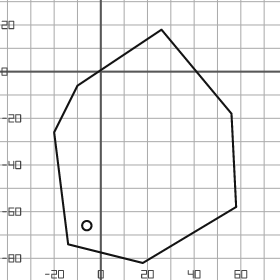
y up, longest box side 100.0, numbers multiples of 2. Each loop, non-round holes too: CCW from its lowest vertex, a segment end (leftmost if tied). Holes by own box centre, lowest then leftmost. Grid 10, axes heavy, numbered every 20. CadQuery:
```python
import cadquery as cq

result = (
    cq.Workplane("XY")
    .moveTo(18.0, -82.0)
    .lineTo(58.0, -58.0)
    .lineTo(56.0, -18.0)
    .lineTo(26.0, 18.0)
    .lineTo(-10.0, -6.0)
    .lineTo(-20.0, -26.0)
    .lineTo(-14.0, -74.0)
    .close()
    .moveTo(-6.0, -66.0)
    .circle(2.0)
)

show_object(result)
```